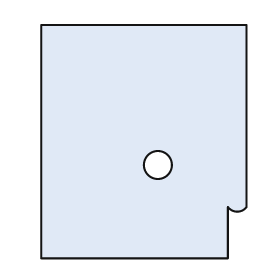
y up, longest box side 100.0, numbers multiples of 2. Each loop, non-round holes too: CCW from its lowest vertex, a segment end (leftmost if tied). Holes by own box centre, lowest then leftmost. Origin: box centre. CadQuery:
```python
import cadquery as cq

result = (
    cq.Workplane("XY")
    .moveTo(-44.0, -50.0)
    .lineTo(36.0, -50.0)
    .lineTo(36.0, -28.0)
    .threePointArc((40.0, -30.0), (44.0, -28.0))
    .lineTo(44.0, 50.0)
    .lineTo(-44.0, 50.0)
    .close()
    .moveTo(6.0, -10.0)
    .circle(6.0)
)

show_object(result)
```